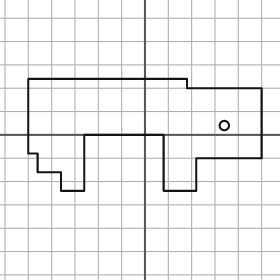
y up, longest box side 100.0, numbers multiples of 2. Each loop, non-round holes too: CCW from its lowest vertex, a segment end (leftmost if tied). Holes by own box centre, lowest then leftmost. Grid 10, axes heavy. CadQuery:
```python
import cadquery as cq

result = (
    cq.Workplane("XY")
    .moveTo(-36.0, -24.0)
    .lineTo(-26.0, -24.0)
    .lineTo(-26.0, 0.0)
    .lineTo(8.0, 0.0)
    .lineTo(8.0, -24.0)
    .lineTo(22.0, -24.0)
    .lineTo(22.0, -10.0)
    .lineTo(50.0, -10.0)
    .lineTo(50.0, 20.0)
    .lineTo(18.0, 20.0)
    .lineTo(18.0, 24.0)
    .lineTo(-50.0, 24.0)
    .lineTo(-50.0, -8.0)
    .lineTo(-46.0, -8.0)
    .lineTo(-46.0, -16.0)
    .lineTo(-36.0, -16.0)
    .close()
    .moveTo(34.0, 4.0)
    .circle(2.0)
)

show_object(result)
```